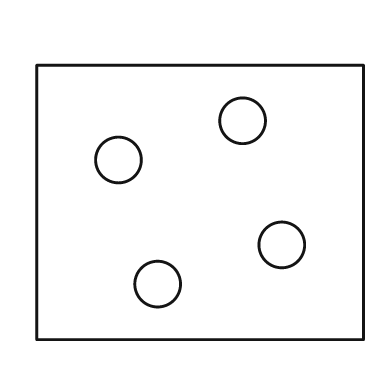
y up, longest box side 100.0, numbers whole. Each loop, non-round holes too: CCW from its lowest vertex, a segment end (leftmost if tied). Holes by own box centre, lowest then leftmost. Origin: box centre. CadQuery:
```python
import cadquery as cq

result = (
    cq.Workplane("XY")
    .moveTo(-50.0, -42.0)
    .lineTo(50.0, -42.0)
    .lineTo(50.0, 42.0)
    .lineTo(-50.0, 42.0)
    .close()
    .moveTo(-13.0, -25.0)
    .circle(7.0)
    .moveTo(25.0, -13.0)
    .circle(7.0)
    .moveTo(-25.0, 13.0)
    .circle(7.0)
    .moveTo(13.0, 25.0)
    .circle(7.0)
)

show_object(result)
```